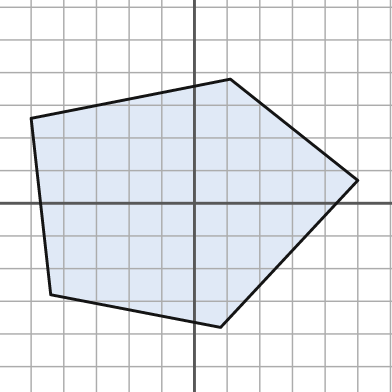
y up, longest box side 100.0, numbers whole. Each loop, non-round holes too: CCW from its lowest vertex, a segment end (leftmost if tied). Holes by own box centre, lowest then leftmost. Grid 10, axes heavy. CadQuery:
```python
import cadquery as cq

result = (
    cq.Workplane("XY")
    .moveTo(8.0, -38.0)
    .lineTo(50.0, 7.0)
    .lineTo(11.0, 38.0)
    .lineTo(-50.0, 26.0)
    .lineTo(-44.0, -28.0)
    .close()
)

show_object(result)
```